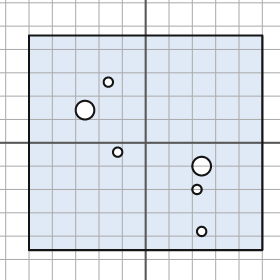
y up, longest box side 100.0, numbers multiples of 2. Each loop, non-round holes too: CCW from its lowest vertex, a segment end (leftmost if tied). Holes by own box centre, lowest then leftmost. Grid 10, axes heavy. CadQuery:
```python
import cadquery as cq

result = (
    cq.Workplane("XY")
    .moveTo(-50.0, -46.0)
    .lineTo(50.0, -46.0)
    .lineTo(50.0, 46.0)
    .lineTo(-50.0, 46.0)
    .close()
    .moveTo(24.0, -38.0)
    .circle(2.0)
    .moveTo(22.0, -20.0)
    .circle(2.0)
    .moveTo(24.0, -10.0)
    .circle(4.0)
    .moveTo(-12.0, -4.0)
    .circle(2.0)
    .moveTo(-26.0, 14.0)
    .circle(4.0)
    .moveTo(-16.0, 26.0)
    .circle(2.0)
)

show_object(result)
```